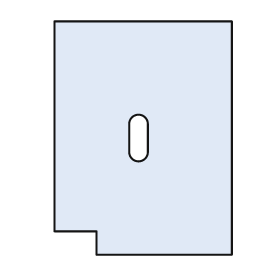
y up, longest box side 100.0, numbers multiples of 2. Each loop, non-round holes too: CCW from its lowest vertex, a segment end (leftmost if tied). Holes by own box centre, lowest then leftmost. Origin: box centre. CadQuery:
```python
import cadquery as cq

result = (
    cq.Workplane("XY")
    .moveTo(-20.0, -50.0)
    .lineTo(38.0, -50.0)
    .lineTo(38.0, 50.0)
    .lineTo(-38.0, 50.0)
    .lineTo(-38.0, -40.0)
    .lineTo(-20.0, -40.0)
    .close()
    .moveTo(-6.0, -6.0)
    .threePointArc((-2.0, -10.0), (2.0, -6.0))
    .lineTo(2.0, 6.0)
    .threePointArc((-2.0, 10.0), (-6.0, 6.0))
    .close()
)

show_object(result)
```